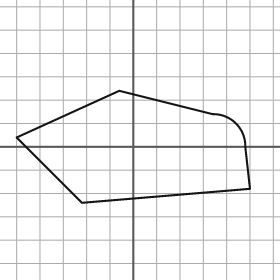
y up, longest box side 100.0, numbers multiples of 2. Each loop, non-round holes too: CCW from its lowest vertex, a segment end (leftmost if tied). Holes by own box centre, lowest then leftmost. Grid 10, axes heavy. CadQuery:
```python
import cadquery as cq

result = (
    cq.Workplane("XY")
    .moveTo(-22.0, -24.0)
    .lineTo(50.0, -18.0)
    .lineTo(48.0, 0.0)
    .threePointArc((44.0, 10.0), (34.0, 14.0))
    .lineTo(-6.0, 24.0)
    .lineTo(-50.0, 4.0)
    .close()
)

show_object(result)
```